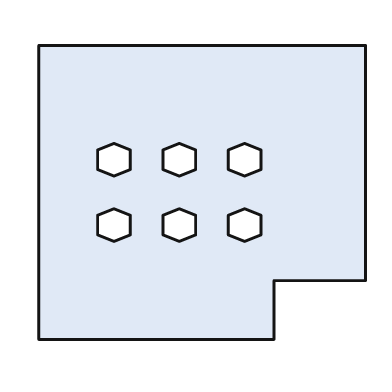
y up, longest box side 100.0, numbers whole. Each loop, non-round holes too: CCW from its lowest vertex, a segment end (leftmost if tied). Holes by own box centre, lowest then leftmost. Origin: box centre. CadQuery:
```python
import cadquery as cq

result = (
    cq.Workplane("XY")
    .moveTo(-50.0, -45.0)
    .lineTo(22.0, -45.0)
    .lineTo(22.0, -27.0)
    .lineTo(50.0, -27.0)
    .lineTo(50.0, 45.0)
    .lineTo(-50.0, 45.0)
    .close()
    .moveTo(-27.0, -15.0)
    .lineTo(-22.0, -13.0)
    .lineTo(-22.0, -7.0)
    .lineTo(-27.0, -5.0)
    .lineTo(-32.0, -7.0)
    .lineTo(-32.0, -13.0)
    .close()
    .moveTo(-7.0, -15.0)
    .lineTo(-2.0, -13.0)
    .lineTo(-2.0, -7.0)
    .lineTo(-7.0, -5.0)
    .lineTo(-12.0, -7.0)
    .lineTo(-12.0, -13.0)
    .close()
    .moveTo(13.0, -15.0)
    .lineTo(18.0, -13.0)
    .lineTo(18.0, -7.0)
    .lineTo(13.0, -5.0)
    .lineTo(8.0, -7.0)
    .lineTo(8.0, -13.0)
    .close()
    .moveTo(-27.0, 5.0)
    .lineTo(-22.0, 7.0)
    .lineTo(-22.0, 13.0)
    .lineTo(-27.0, 15.0)
    .lineTo(-32.0, 13.0)
    .lineTo(-32.0, 7.0)
    .close()
    .moveTo(-7.0, 5.0)
    .lineTo(-2.0, 7.0)
    .lineTo(-2.0, 13.0)
    .lineTo(-7.0, 15.0)
    .lineTo(-12.0, 13.0)
    .lineTo(-12.0, 7.0)
    .close()
    .moveTo(13.0, 5.0)
    .lineTo(18.0, 7.0)
    .lineTo(18.0, 13.0)
    .lineTo(13.0, 15.0)
    .lineTo(8.0, 13.0)
    .lineTo(8.0, 7.0)
    .close()
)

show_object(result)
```